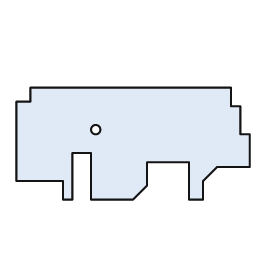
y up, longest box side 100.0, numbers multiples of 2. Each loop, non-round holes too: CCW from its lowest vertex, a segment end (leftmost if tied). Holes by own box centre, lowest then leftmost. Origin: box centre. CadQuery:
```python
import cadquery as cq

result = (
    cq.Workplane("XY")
    .moveTo(-30.0, -24.0)
    .lineTo(-26.0, -24.0)
    .lineTo(-26.0, -4.0)
    .lineTo(-18.0, -4.0)
    .lineTo(-18.0, -24.0)
    .lineTo(0.0, -24.0)
    .lineTo(6.0, -18.0)
    .lineTo(6.0, -8.0)
    .lineTo(24.0, -8.0)
    .lineTo(24.0, -24.0)
    .lineTo(30.0, -24.0)
    .lineTo(30.0, -16.0)
    .lineTo(36.0, -10.0)
    .lineTo(50.0, -10.0)
    .lineTo(50.0, 4.0)
    .lineTo(46.0, 4.0)
    .lineTo(46.0, 16.0)
    .lineTo(42.0, 16.0)
    .lineTo(42.0, 24.0)
    .lineTo(-44.0, 24.0)
    .lineTo(-44.0, 18.0)
    .lineTo(-50.0, 18.0)
    .lineTo(-50.0, -16.0)
    .lineTo(-30.0, -16.0)
    .close()
    .moveTo(-16.0, 6.0)
    .circle(2.0)
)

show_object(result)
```